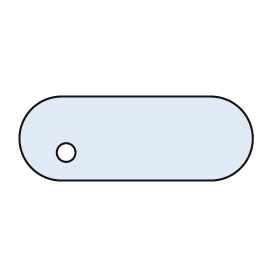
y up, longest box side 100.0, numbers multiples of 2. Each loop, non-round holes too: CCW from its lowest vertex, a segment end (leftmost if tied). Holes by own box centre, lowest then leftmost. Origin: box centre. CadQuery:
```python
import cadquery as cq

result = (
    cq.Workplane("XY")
    .moveTo(-32.0, -18.0)
    .lineTo(32.0, -18.0)
    .threePointArc((50.0, 0.0), (32.0, 18.0))
    .lineTo(-32.0, 18.0)
    .threePointArc((-50.0, 0.0), (-32.0, -18.0))
    .close()
    .moveTo(-30.0, -6.0)
    .circle(4.0)
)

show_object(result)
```